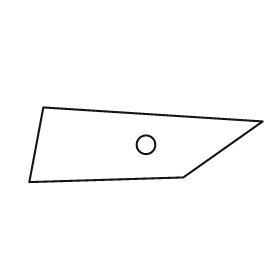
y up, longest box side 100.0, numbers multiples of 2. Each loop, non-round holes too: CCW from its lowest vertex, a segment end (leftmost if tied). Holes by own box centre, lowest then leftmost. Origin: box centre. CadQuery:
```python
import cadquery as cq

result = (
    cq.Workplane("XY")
    .moveTo(-50.0, -16.0)
    .lineTo(16.0, -14.0)
    .lineTo(50.0, 10.0)
    .lineTo(-44.0, 16.0)
    .close()
    .moveTo(0.0, 0.0)
    .circle(4.0)
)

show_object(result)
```